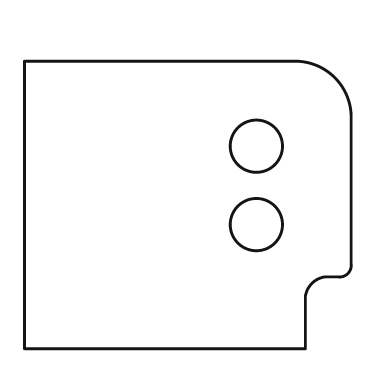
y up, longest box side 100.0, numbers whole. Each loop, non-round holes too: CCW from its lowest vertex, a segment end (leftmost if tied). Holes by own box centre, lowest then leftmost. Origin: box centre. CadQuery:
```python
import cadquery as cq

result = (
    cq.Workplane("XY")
    .moveTo(-50.0, -44.0)
    .lineTo(36.0, -44.0)
    .lineTo(36.0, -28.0)
    .threePointArc((38.0, -24.0), (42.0, -22.0))
    .lineTo(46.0, -22.0)
    .threePointArc((49.0, -21.0), (50.0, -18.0))
    .lineTo(50.0, 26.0)
    .threePointArc((45.0, 39.0), (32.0, 44.0))
    .lineTo(-50.0, 44.0)
    .close()
    .moveTo(21.0, -6.0)
    .circle(8.0)
    .moveTo(21.0, 18.0)
    .circle(8.0)
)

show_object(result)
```